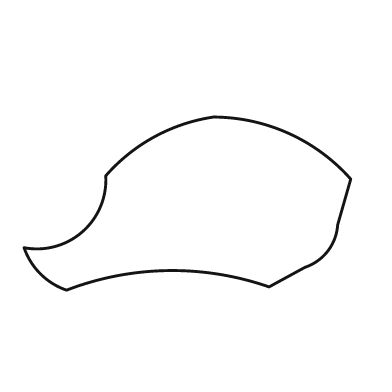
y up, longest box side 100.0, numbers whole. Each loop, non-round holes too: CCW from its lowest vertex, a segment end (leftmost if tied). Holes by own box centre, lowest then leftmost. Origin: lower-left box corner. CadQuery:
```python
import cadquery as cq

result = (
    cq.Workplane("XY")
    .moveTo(13.0, 0.0)
    .threePointArc((44.0, 6.0), (75.0, 1.0))
    .lineTo(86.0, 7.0)
    .threePointArc((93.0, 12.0), (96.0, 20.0))
    .lineTo(100.0, 34.0)
    .threePointArc((81.0, 48.0), (58.0, 53.0))
    .threePointArc((40.0, 47.0), (25.0, 35.0))
    .threePointArc((18.0, 18.0), (0.0, 13.0))
    .threePointArc((5.0, 5.0), (13.0, 0.0))
    .close()
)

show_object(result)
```